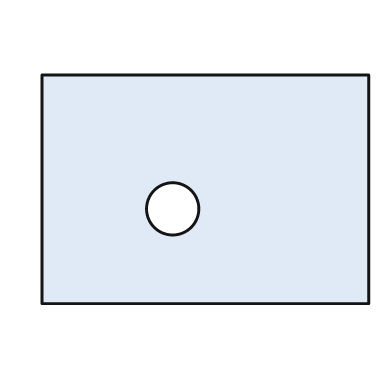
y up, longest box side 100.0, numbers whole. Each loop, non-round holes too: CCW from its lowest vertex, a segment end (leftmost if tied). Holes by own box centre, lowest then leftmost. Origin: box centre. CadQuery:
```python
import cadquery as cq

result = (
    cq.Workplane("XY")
    .moveTo(-50.0, -35.0)
    .lineTo(50.0, -35.0)
    .lineTo(50.0, 35.0)
    .lineTo(-50.0, 35.0)
    .close()
    .moveTo(-10.0, -6.0)
    .circle(8.0)
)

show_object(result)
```